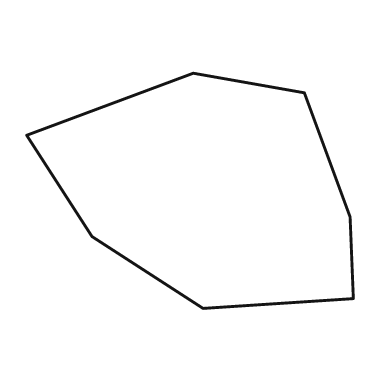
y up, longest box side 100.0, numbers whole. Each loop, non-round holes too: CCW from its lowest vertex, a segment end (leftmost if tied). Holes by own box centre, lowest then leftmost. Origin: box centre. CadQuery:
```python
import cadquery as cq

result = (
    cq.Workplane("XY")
    .moveTo(4.0, -36.0)
    .lineTo(50.0, -33.0)
    .lineTo(49.0, -8.0)
    .lineTo(35.0, 30.0)
    .lineTo(1.0, 36.0)
    .lineTo(-50.0, 17.0)
    .lineTo(-30.0, -14.0)
    .close()
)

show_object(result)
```